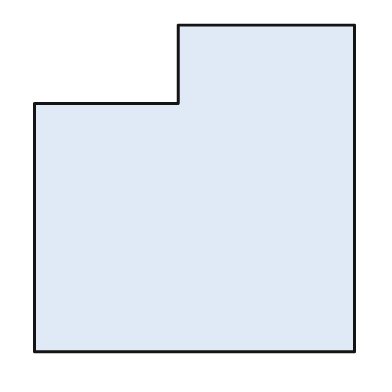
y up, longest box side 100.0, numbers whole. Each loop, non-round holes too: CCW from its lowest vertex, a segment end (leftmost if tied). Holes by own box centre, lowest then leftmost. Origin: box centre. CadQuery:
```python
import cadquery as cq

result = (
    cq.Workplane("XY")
    .moveTo(-49.0, -50.0)
    .lineTo(49.0, -50.0)
    .lineTo(49.0, 50.0)
    .lineTo(-5.0, 50.0)
    .lineTo(-5.0, 26.0)
    .lineTo(-49.0, 26.0)
    .close()
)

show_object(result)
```